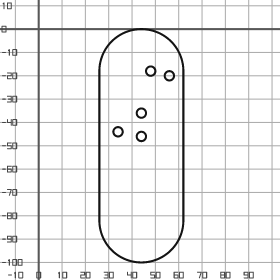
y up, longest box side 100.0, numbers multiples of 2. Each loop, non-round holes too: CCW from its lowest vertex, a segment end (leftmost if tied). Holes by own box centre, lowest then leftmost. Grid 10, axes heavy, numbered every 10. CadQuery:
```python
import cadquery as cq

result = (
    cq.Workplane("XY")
    .moveTo(26.0, -82.0)
    .threePointArc((44.0, -100.0), (62.0, -82.0))
    .lineTo(62.0, -18.0)
    .threePointArc((44.0, 0.0), (26.0, -18.0))
    .close()
    .moveTo(44.0, -46.0)
    .circle(2.0)
    .moveTo(34.0, -44.0)
    .circle(2.0)
    .moveTo(44.0, -36.0)
    .circle(2.0)
    .moveTo(56.0, -20.0)
    .circle(2.0)
    .moveTo(48.0, -18.0)
    .circle(2.0)
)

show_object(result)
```